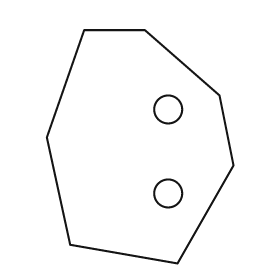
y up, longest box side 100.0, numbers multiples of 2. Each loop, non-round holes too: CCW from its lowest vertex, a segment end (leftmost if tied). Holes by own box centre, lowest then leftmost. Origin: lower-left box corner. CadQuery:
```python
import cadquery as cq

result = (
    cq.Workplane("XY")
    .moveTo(56.0, 0.0)
    .lineTo(80.0, 42.0)
    .lineTo(74.0, 72.0)
    .lineTo(42.0, 100.0)
    .lineTo(16.0, 100.0)
    .lineTo(0.0, 54.0)
    .lineTo(10.0, 8.0)
    .close()
    .moveTo(52.0, 30.0)
    .circle(6.0)
    .moveTo(52.0, 66.0)
    .circle(6.0)
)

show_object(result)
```